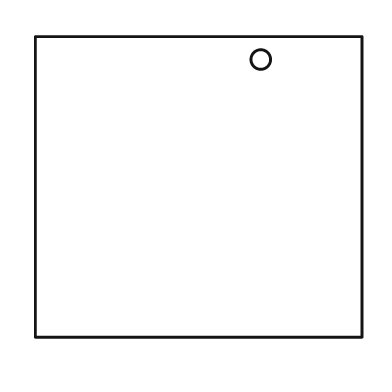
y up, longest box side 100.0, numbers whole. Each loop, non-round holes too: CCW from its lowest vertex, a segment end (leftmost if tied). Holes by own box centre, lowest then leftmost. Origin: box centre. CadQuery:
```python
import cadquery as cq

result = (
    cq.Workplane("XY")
    .moveTo(-50.0, -46.0)
    .lineTo(50.0, -46.0)
    .lineTo(50.0, 46.0)
    .lineTo(-50.0, 46.0)
    .close()
    .moveTo(19.0, 39.0)
    .circle(3.0)
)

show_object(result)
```